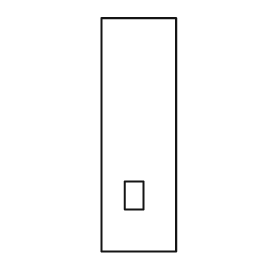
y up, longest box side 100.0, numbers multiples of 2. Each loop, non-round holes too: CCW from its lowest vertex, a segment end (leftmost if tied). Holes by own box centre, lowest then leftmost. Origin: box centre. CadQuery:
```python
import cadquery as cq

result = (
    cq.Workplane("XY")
    .moveTo(-16.0, -50.0)
    .lineTo(16.0, -50.0)
    .lineTo(16.0, 50.0)
    .lineTo(-16.0, 50.0)
    .close()
    .moveTo(-6.0, -32.0)
    .lineTo(2.0, -32.0)
    .lineTo(2.0, -20.0)
    .lineTo(-6.0, -20.0)
    .close()
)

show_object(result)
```